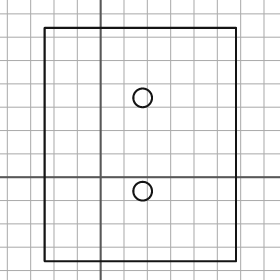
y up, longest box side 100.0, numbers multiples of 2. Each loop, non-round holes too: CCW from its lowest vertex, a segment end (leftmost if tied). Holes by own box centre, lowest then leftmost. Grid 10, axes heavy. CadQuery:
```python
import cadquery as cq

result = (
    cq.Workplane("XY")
    .moveTo(-24.0, -36.0)
    .lineTo(58.0, -36.0)
    .lineTo(58.0, 64.0)
    .lineTo(-24.0, 64.0)
    .close()
    .moveTo(18.0, -6.0)
    .circle(4.0)
    .moveTo(18.0, 34.0)
    .circle(4.0)
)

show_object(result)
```